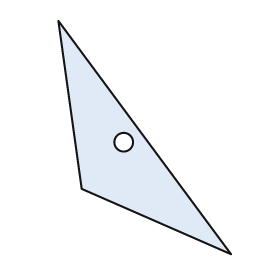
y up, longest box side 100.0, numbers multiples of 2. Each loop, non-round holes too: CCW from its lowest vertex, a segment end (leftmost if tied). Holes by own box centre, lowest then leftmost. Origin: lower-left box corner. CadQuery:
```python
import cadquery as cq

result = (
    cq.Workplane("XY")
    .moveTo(74.0, 0.0)
    .lineTo(0.0, 100.0)
    .lineTo(10.0, 28.0)
    .close()
    .moveTo(28.0, 48.0)
    .circle(4.0)
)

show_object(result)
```